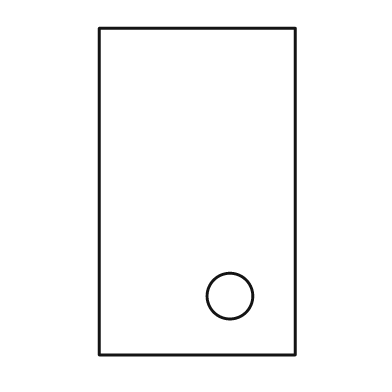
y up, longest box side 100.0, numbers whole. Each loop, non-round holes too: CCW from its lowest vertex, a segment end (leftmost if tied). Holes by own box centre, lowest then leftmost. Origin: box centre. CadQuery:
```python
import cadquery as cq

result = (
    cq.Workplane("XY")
    .moveTo(-30.0, -50.0)
    .lineTo(30.0, -50.0)
    .lineTo(30.0, 50.0)
    .lineTo(-30.0, 50.0)
    .close()
    .moveTo(10.0, -32.0)
    .circle(7.0)
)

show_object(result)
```